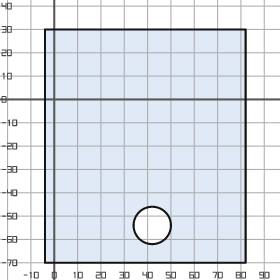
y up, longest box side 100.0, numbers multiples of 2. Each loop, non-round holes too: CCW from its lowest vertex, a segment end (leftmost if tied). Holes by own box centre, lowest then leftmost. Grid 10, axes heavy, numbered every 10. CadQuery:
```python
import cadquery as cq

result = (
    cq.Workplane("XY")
    .moveTo(-4.0, -70.0)
    .lineTo(82.0, -70.0)
    .lineTo(82.0, 30.0)
    .lineTo(-4.0, 30.0)
    .close()
    .moveTo(42.0, -54.0)
    .circle(8.0)
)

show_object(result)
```